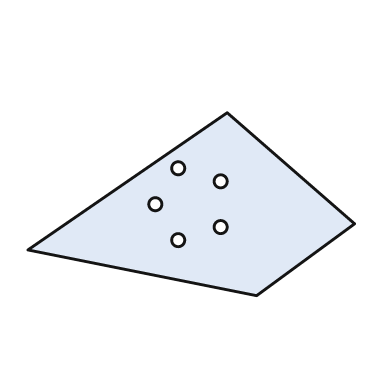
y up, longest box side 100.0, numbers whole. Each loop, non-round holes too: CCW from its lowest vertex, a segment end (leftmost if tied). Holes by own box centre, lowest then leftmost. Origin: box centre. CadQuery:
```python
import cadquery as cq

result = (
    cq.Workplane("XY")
    .moveTo(20.0, -28.0)
    .lineTo(50.0, -6.0)
    .lineTo(11.0, 28.0)
    .lineTo(-50.0, -14.0)
    .close()
    .moveTo(-4.0, -11.0)
    .circle(2.0)
    .moveTo(9.0, -7.0)
    .circle(2.0)
    .moveTo(-11.0, 0.0)
    .circle(2.0)
    .moveTo(9.0, 7.0)
    .circle(2.0)
    .moveTo(-4.0, 11.0)
    .circle(2.0)
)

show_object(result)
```